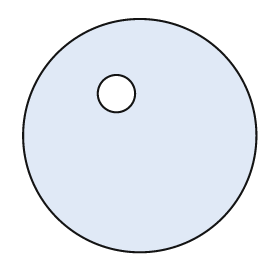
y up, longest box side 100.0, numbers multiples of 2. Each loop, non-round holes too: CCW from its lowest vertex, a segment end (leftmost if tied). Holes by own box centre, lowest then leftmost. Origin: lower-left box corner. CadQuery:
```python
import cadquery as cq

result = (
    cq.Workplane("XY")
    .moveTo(50.0, 50.0)
    .circle(50.0)
    .moveTo(40.0, 68.0)
    .circle(8.0)
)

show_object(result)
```